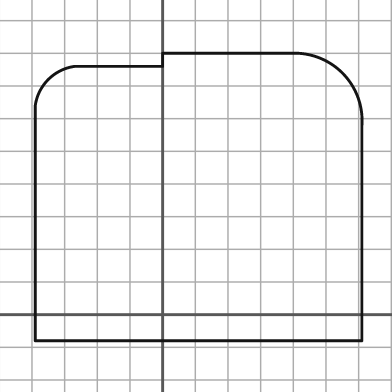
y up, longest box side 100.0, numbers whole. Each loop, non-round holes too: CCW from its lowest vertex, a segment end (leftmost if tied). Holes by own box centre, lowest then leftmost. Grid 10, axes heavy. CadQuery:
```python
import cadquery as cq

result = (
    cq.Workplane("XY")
    .moveTo(-39.0, -8.0)
    .lineTo(61.0, -8.0)
    .lineTo(61.0, 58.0)
    .threePointArc((55.0, 74.0), (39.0, 80.0))
    .lineTo(0.0, 80.0)
    .lineTo(0.0, 76.0)
    .lineTo(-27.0, 76.0)
    .threePointArc((-35.0, 72.0), (-39.0, 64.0))
    .close()
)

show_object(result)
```